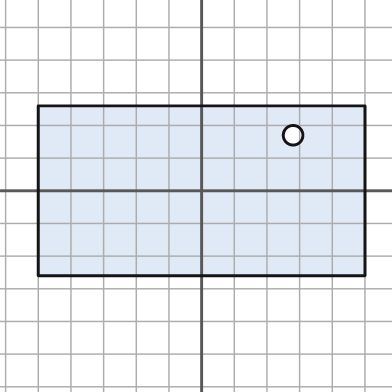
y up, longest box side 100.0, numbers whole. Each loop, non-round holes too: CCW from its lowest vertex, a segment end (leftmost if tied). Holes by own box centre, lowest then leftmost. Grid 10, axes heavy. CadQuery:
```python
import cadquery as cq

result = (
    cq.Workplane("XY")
    .moveTo(-50.0, -26.0)
    .lineTo(50.0, -26.0)
    .lineTo(50.0, 26.0)
    .lineTo(-50.0, 26.0)
    .close()
    .moveTo(28.0, 17.0)
    .circle(3.0)
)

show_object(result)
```